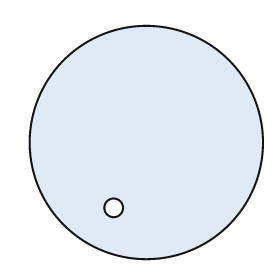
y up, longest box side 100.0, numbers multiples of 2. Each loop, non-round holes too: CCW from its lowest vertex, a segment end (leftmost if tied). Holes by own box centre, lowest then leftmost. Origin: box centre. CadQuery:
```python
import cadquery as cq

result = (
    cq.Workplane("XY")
    .moveTo(0.0, 0.0)
    .circle(50.0)
    .moveTo(-14.0, -28.0)
    .circle(4.0)
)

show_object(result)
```